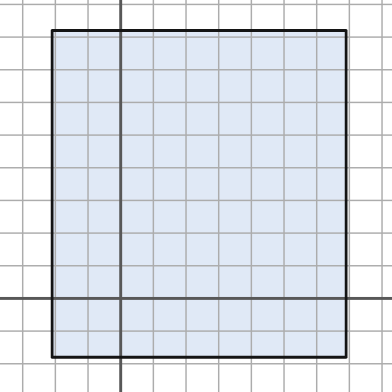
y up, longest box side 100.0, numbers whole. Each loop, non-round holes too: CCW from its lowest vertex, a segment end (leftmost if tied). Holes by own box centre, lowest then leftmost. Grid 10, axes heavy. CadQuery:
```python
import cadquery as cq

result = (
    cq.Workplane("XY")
    .moveTo(-21.0, -18.0)
    .lineTo(69.0, -18.0)
    .lineTo(69.0, 82.0)
    .lineTo(-21.0, 82.0)
    .close()
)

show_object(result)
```